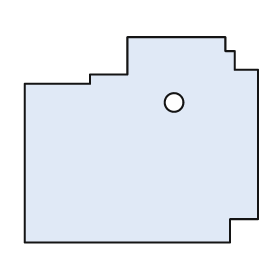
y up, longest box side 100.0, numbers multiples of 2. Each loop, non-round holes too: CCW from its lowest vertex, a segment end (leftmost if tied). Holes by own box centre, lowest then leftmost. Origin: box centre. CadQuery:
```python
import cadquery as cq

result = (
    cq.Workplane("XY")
    .moveTo(-50.0, -44.0)
    .lineTo(38.0, -44.0)
    .lineTo(38.0, -34.0)
    .lineTo(50.0, -34.0)
    .lineTo(50.0, 30.0)
    .lineTo(40.0, 30.0)
    .lineTo(40.0, 38.0)
    .lineTo(36.0, 38.0)
    .lineTo(36.0, 44.0)
    .lineTo(-6.0, 44.0)
    .lineTo(-6.0, 28.0)
    .lineTo(-22.0, 28.0)
    .lineTo(-22.0, 24.0)
    .lineTo(-50.0, 24.0)
    .close()
    .moveTo(14.0, 16.0)
    .circle(4.0)
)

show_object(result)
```